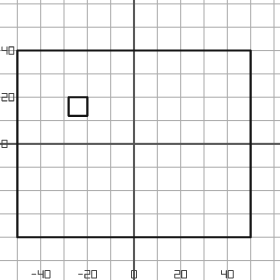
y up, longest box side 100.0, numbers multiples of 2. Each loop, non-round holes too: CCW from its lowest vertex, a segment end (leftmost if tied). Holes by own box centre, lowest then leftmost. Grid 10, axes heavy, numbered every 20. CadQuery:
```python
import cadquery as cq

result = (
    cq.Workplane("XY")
    .moveTo(-50.0, -40.0)
    .lineTo(50.0, -40.0)
    .lineTo(50.0, 40.0)
    .lineTo(-50.0, 40.0)
    .close()
    .moveTo(-28.0, 12.0)
    .lineTo(-20.0, 12.0)
    .lineTo(-20.0, 20.0)
    .lineTo(-28.0, 20.0)
    .close()
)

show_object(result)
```